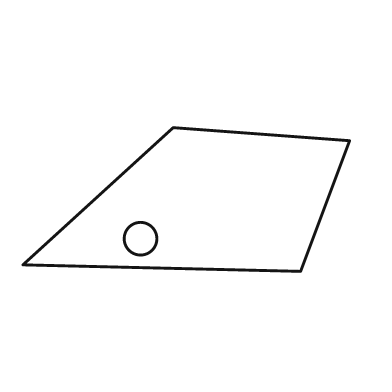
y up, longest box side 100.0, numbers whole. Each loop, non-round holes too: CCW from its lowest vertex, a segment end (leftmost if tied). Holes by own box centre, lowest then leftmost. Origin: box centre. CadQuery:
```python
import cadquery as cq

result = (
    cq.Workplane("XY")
    .moveTo(35.0, -22.0)
    .lineTo(50.0, 18.0)
    .lineTo(-4.0, 22.0)
    .lineTo(-50.0, -20.0)
    .close()
    .moveTo(-14.0, -12.0)
    .circle(5.0)
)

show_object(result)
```